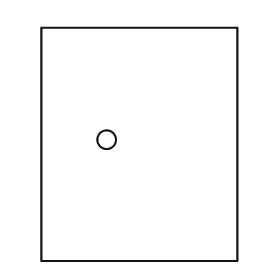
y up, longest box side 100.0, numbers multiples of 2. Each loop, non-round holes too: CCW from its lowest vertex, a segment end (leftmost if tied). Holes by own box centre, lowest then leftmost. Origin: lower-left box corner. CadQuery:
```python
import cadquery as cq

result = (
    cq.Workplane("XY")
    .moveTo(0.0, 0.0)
    .lineTo(84.0, 0.0)
    .lineTo(84.0, 100.0)
    .lineTo(0.0, 100.0)
    .close()
    .moveTo(28.0, 52.0)
    .circle(4.0)
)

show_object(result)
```